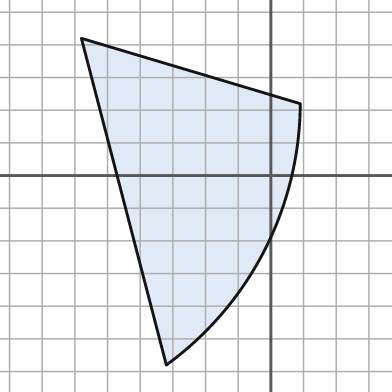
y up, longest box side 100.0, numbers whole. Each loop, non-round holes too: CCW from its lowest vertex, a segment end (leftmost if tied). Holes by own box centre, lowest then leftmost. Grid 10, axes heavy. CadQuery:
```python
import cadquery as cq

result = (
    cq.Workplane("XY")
    .moveTo(-32.0, -58.0)
    .threePointArc((-2.0, -23.0), (9.0, 22.0))
    .lineTo(-58.0, 42.0)
    .close()
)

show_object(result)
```